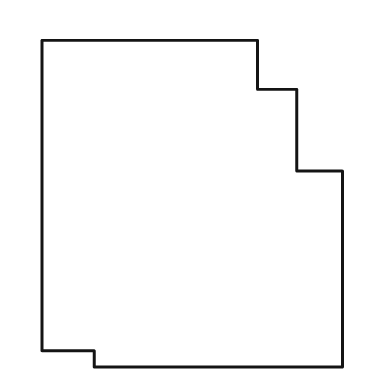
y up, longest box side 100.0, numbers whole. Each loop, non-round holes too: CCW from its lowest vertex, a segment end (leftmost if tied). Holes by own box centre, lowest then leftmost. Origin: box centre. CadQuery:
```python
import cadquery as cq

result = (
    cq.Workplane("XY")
    .moveTo(-30.0, -50.0)
    .lineTo(46.0, -50.0)
    .lineTo(46.0, 10.0)
    .lineTo(32.0, 10.0)
    .lineTo(32.0, 35.0)
    .lineTo(20.0, 35.0)
    .lineTo(20.0, 50.0)
    .lineTo(-46.0, 50.0)
    .lineTo(-46.0, -45.0)
    .lineTo(-30.0, -45.0)
    .close()
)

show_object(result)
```